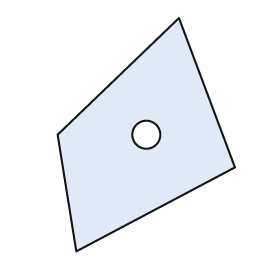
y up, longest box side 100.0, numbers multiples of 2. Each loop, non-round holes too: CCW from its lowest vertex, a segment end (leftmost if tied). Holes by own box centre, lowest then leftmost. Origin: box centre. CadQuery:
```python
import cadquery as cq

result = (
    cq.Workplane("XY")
    .moveTo(-30.0, -50.0)
    .lineTo(38.0, -14.0)
    .lineTo(14.0, 50.0)
    .lineTo(-38.0, 0.0)
    .close()
    .moveTo(0.0, 0.0)
    .circle(6.0)
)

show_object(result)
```